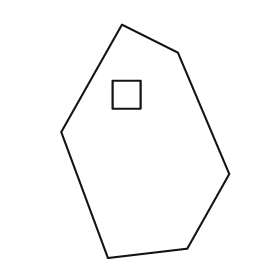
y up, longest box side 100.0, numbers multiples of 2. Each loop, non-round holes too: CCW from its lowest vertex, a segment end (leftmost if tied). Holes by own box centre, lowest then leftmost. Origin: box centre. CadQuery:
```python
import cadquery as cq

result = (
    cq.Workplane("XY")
    .moveTo(-16.0, -50.0)
    .lineTo(18.0, -46.0)
    .lineTo(36.0, -14.0)
    .lineTo(14.0, 38.0)
    .lineTo(-10.0, 50.0)
    .lineTo(-36.0, 4.0)
    .close()
    .moveTo(-14.0, 14.0)
    .lineTo(-2.0, 14.0)
    .lineTo(-2.0, 26.0)
    .lineTo(-14.0, 26.0)
    .close()
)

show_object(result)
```